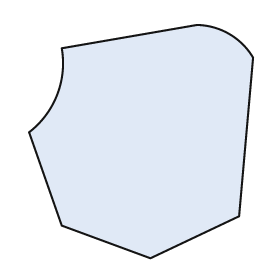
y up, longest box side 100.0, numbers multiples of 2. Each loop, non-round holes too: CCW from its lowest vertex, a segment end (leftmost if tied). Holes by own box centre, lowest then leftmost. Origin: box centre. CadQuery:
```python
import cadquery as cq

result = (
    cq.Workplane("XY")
    .moveTo(4.0, -50.0)
    .lineTo(42.0, -32.0)
    .lineTo(48.0, 36.0)
    .threePointArc((38.0, 46.0), (24.0, 50.0))
    .lineTo(-34.0, 40.0)
    .threePointArc((-36.0, 20.0), (-48.0, 4.0))
    .lineTo(-34.0, -36.0)
    .close()
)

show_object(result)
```